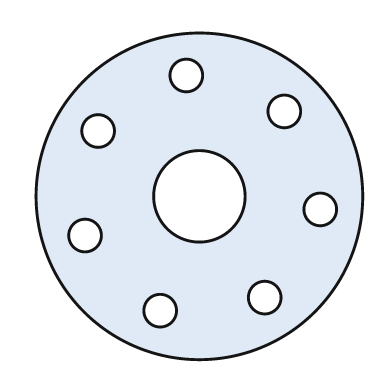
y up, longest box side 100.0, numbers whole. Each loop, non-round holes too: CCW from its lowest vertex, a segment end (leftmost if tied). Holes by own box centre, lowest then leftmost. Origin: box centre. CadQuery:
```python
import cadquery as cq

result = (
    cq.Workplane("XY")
    .moveTo(0.0, 0.0)
    .circle(50.0)
    .moveTo(-12.0, -35.0)
    .circle(5.0)
    .moveTo(20.0, -31.0)
    .circle(5.0)
    .moveTo(-35.0, -12.0)
    .circle(5.0)
    .moveTo(37.0, -4.0)
    .circle(5.0)
    .moveTo(0.0, 0.0)
    .circle(14.0)
    .moveTo(-31.0, 20.0)
    .circle(5.0)
    .moveTo(26.0, 26.0)
    .circle(5.0)
    .moveTo(-4.0, 37.0)
    .circle(5.0)
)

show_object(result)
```